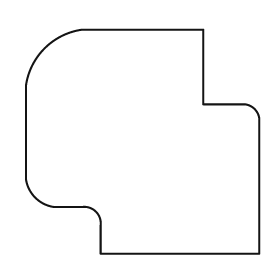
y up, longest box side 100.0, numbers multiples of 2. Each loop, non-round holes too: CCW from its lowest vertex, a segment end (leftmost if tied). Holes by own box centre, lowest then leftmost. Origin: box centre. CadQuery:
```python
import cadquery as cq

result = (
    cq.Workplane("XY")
    .moveTo(-18.0, -48.0)
    .lineTo(50.0, -48.0)
    .lineTo(50.0, 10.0)
    .threePointArc((48.0, 14.0), (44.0, 16.0))
    .lineTo(26.0, 16.0)
    .lineTo(26.0, 48.0)
    .lineTo(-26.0, 48.0)
    .threePointArc((-42.0, 40.0), (-50.0, 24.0))
    .lineTo(-50.0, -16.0)
    .threePointArc((-46.0, -24.0), (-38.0, -28.0))
    .lineTo(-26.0, -28.0)
    .threePointArc((-20.0, -30.0), (-18.0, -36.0))
    .close()
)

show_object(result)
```